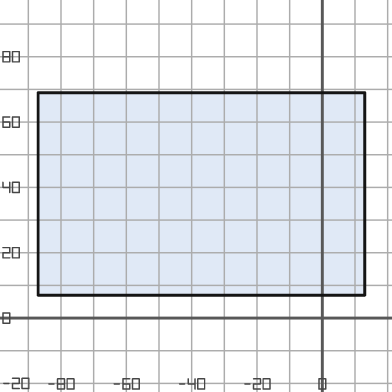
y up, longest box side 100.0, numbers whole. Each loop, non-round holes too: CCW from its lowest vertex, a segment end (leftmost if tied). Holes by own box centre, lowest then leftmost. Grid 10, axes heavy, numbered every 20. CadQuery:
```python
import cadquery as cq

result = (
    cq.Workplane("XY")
    .moveTo(-87.0, 7.0)
    .lineTo(13.0, 7.0)
    .lineTo(13.0, 69.0)
    .lineTo(-87.0, 69.0)
    .close()
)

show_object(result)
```